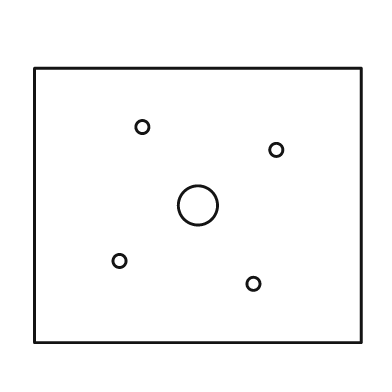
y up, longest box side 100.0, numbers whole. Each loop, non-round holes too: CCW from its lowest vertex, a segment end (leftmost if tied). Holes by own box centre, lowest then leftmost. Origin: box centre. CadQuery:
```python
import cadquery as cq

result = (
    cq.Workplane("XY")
    .moveTo(-50.0, -42.0)
    .lineTo(50.0, -42.0)
    .lineTo(50.0, 42.0)
    .lineTo(-50.0, 42.0)
    .close()
    .moveTo(17.0, -24.0)
    .circle(2.0)
    .moveTo(-24.0, -17.0)
    .circle(2.0)
    .moveTo(0.0, 0.0)
    .circle(6.0)
    .moveTo(24.0, 17.0)
    .circle(2.0)
    .moveTo(-17.0, 24.0)
    .circle(2.0)
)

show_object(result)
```